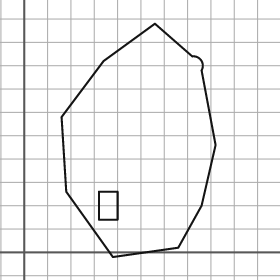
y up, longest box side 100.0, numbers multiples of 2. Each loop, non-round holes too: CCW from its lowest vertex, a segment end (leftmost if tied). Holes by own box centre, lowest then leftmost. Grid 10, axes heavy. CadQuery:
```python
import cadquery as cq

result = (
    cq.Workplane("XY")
    .moveTo(38.0, -2.0)
    .lineTo(66.0, 2.0)
    .lineTo(76.0, 20.0)
    .lineTo(82.0, 46.0)
    .lineTo(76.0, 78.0)
    .threePointArc((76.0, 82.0), (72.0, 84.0))
    .lineTo(56.0, 98.0)
    .lineTo(34.0, 82.0)
    .lineTo(16.0, 58.0)
    .lineTo(18.0, 26.0)
    .close()
    .moveTo(32.0, 14.0)
    .lineTo(40.0, 14.0)
    .lineTo(40.0, 26.0)
    .lineTo(32.0, 26.0)
    .close()
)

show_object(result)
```